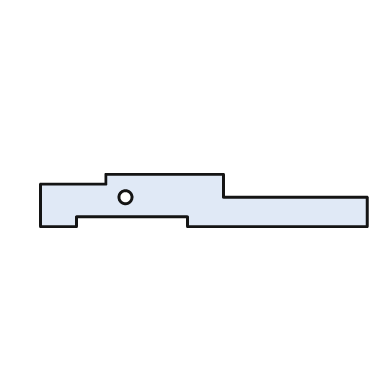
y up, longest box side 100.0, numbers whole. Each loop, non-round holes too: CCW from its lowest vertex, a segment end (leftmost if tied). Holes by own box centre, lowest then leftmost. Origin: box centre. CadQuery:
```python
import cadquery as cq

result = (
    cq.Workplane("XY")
    .moveTo(-50.0, -8.0)
    .lineTo(-39.0, -8.0)
    .lineTo(-39.0, -5.0)
    .lineTo(-5.0, -5.0)
    .lineTo(-5.0, -8.0)
    .lineTo(50.0, -8.0)
    .lineTo(50.0, 1.0)
    .lineTo(6.0, 1.0)
    .lineTo(6.0, 8.0)
    .lineTo(-30.0, 8.0)
    .lineTo(-30.0, 5.0)
    .lineTo(-50.0, 5.0)
    .close()
    .moveTo(-24.0, 1.0)
    .circle(2.0)
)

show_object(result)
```